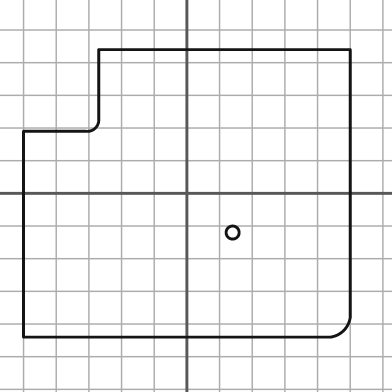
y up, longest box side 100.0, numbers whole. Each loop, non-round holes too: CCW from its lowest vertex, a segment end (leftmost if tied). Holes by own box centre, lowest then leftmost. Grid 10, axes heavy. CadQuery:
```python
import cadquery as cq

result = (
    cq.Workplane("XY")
    .moveTo(-50.0, -44.0)
    .lineTo(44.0, -44.0)
    .threePointArc((48.0, -42.0), (50.0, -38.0))
    .lineTo(50.0, 44.0)
    .lineTo(-27.0, 44.0)
    .lineTo(-27.0, 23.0)
    .threePointArc((-28.0, 20.0), (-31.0, 19.0))
    .lineTo(-50.0, 19.0)
    .close()
    .moveTo(14.0, -12.0)
    .circle(2.0)
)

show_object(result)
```